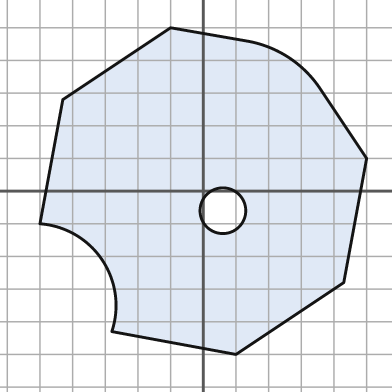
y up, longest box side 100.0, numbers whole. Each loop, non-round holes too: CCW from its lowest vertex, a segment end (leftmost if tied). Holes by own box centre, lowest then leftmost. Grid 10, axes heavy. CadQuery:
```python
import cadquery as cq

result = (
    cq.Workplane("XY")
    .moveTo(10.0, -50.0)
    .lineTo(43.0, -28.0)
    .lineTo(50.0, 10.0)
    .lineTo(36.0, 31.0)
    .threePointArc((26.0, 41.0), (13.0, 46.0))
    .lineTo(-10.0, 50.0)
    .lineTo(-43.0, 28.0)
    .lineTo(-50.0, -10.0)
    .threePointArc((-31.0, -21.0), (-28.0, -43.0))
    .close()
    .moveTo(6.0, -6.0)
    .circle(7.0)
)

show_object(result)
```